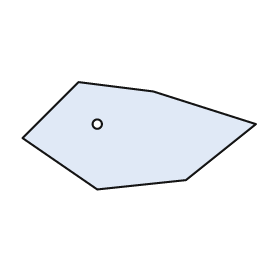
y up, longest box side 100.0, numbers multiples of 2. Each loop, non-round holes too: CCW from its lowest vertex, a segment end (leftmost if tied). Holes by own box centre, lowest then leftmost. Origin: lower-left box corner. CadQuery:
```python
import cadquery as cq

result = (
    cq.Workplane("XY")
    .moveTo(32.0, 0.0)
    .lineTo(70.0, 4.0)
    .lineTo(100.0, 28.0)
    .lineTo(56.0, 42.0)
    .lineTo(24.0, 46.0)
    .lineTo(0.0, 22.0)
    .close()
    .moveTo(32.0, 28.0)
    .circle(2.0)
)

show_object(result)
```